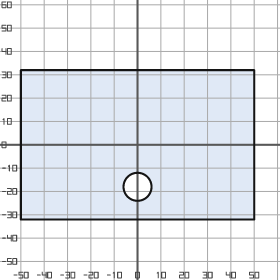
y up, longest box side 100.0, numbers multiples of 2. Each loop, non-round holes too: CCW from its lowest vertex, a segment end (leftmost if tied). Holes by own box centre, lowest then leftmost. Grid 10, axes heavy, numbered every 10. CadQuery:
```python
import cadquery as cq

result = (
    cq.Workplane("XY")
    .moveTo(-50.0, -32.0)
    .lineTo(50.0, -32.0)
    .lineTo(50.0, 32.0)
    .lineTo(-50.0, 32.0)
    .close()
    .moveTo(0.0, -18.0)
    .circle(6.0)
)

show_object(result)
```